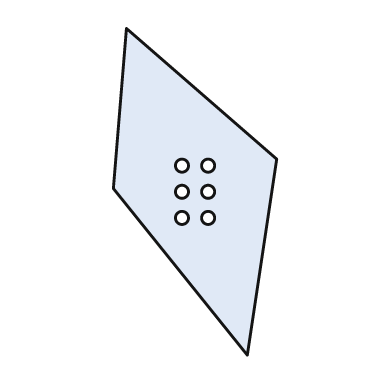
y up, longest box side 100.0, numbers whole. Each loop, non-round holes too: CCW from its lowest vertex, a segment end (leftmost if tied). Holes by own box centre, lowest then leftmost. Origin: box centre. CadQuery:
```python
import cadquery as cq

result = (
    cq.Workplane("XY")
    .moveTo(16.0, -50.0)
    .lineTo(25.0, 10.0)
    .lineTo(-21.0, 50.0)
    .lineTo(-25.0, 1.0)
    .close()
    .moveTo(-4.0, -8.0)
    .circle(2.0)
    .moveTo(4.0, -8.0)
    .circle(2.0)
    .moveTo(-4.0, 0.0)
    .circle(2.0)
    .moveTo(4.0, 0.0)
    .circle(2.0)
    .moveTo(-4.0, 8.0)
    .circle(2.0)
    .moveTo(4.0, 8.0)
    .circle(2.0)
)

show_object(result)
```